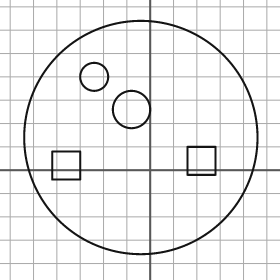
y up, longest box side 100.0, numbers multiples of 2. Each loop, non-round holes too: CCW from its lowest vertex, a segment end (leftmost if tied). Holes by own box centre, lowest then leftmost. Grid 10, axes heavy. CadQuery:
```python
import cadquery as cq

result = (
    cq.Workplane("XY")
    .moveTo(-4.0, 14.0)
    .circle(50.0)
    .moveTo(-42.0, -4.0)
    .lineTo(-30.0, -4.0)
    .lineTo(-30.0, 8.0)
    .lineTo(-42.0, 8.0)
    .close()
    .moveTo(16.0, -2.0)
    .lineTo(28.0, -2.0)
    .lineTo(28.0, 10.0)
    .lineTo(16.0, 10.0)
    .close()
    .moveTo(-8.0, 26.0)
    .circle(8.0)
    .moveTo(-24.0, 40.0)
    .circle(6.0)
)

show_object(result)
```